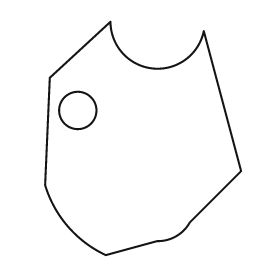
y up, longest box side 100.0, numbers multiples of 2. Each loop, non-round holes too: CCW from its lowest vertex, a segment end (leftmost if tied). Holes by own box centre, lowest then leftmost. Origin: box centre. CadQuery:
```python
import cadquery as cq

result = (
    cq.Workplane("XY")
    .moveTo(-16.0, -50.0)
    .lineTo(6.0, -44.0)
    .threePointArc((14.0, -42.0), (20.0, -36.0))
    .lineTo(42.0, -14.0)
    .lineTo(26.0, 46.0)
    .threePointArc((4.0, 30.0), (-14.0, 50.0))
    .lineTo(-40.0, 26.0)
    .lineTo(-42.0, -20.0)
    .threePointArc((-32.0, -38.0), (-16.0, -50.0))
    .close()
    .moveTo(-28.0, 12.0)
    .circle(8.0)
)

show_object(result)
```